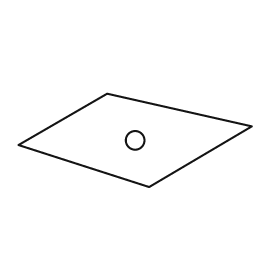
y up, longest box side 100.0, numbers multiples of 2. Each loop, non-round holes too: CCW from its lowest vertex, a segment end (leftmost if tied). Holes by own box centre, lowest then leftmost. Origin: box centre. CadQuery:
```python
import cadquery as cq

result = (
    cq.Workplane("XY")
    .moveTo(6.0, -20.0)
    .lineTo(50.0, 6.0)
    .lineTo(-12.0, 20.0)
    .lineTo(-50.0, -2.0)
    .close()
    .moveTo(0.0, 0.0)
    .circle(4.0)
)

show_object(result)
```